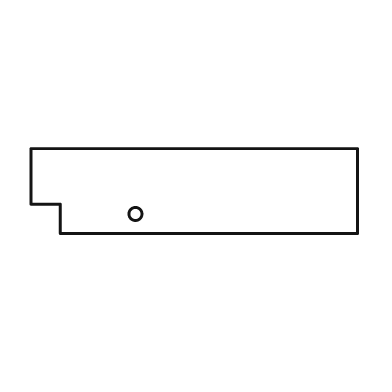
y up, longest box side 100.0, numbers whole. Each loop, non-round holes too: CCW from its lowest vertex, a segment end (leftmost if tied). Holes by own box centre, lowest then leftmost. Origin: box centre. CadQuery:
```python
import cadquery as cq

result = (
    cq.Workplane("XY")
    .moveTo(-41.0, -13.0)
    .lineTo(50.0, -13.0)
    .lineTo(50.0, 13.0)
    .lineTo(-50.0, 13.0)
    .lineTo(-50.0, -4.0)
    .lineTo(-41.0, -4.0)
    .close()
    .moveTo(-18.0, -7.0)
    .circle(2.0)
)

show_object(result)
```